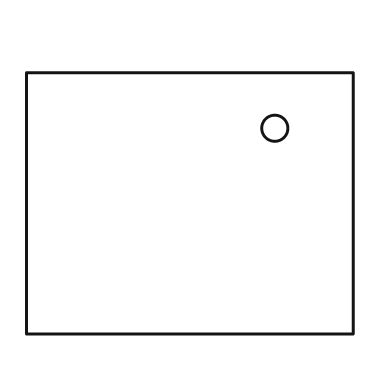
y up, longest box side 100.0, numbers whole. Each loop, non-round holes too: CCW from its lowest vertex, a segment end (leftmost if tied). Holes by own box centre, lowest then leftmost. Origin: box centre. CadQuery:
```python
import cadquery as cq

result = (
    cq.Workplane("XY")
    .moveTo(-50.0, -40.0)
    .lineTo(50.0, -40.0)
    .lineTo(50.0, 40.0)
    .lineTo(-50.0, 40.0)
    .close()
    .moveTo(26.0, 23.0)
    .circle(4.0)
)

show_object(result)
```